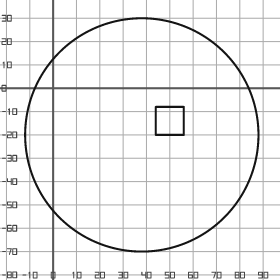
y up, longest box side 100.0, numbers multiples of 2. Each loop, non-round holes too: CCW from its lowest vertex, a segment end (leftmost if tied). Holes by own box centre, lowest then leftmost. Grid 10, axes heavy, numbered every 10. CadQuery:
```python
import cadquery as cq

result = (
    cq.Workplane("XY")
    .moveTo(38.0, -20.0)
    .circle(50.0)
    .moveTo(44.0, -20.0)
    .lineTo(56.0, -20.0)
    .lineTo(56.0, -8.0)
    .lineTo(44.0, -8.0)
    .close()
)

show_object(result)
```